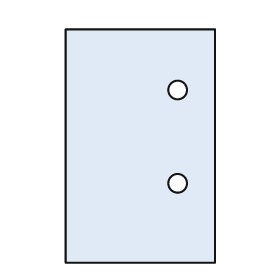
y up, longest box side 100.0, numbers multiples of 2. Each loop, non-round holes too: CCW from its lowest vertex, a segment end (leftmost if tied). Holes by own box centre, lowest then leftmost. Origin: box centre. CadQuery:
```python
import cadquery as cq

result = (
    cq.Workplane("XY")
    .moveTo(-32.0, -50.0)
    .lineTo(32.0, -50.0)
    .lineTo(32.0, 50.0)
    .lineTo(-32.0, 50.0)
    .close()
    .moveTo(16.0, -16.0)
    .circle(4.0)
    .moveTo(16.0, 24.0)
    .circle(4.0)
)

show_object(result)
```